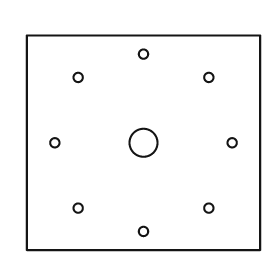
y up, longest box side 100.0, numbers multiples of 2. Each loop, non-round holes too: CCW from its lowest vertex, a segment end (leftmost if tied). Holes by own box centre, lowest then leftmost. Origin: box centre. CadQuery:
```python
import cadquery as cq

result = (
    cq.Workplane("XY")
    .moveTo(-50.0, -46.0)
    .lineTo(50.0, -46.0)
    .lineTo(50.0, 46.0)
    .lineTo(-50.0, 46.0)
    .close()
    .moveTo(0.0, -38.0)
    .circle(2.0)
    .moveTo(-28.0, -28.0)
    .circle(2.0)
    .moveTo(28.0, -28.0)
    .circle(2.0)
    .moveTo(-38.0, 0.0)
    .circle(2.0)
    .moveTo(0.0, 0.0)
    .circle(6.0)
    .moveTo(38.0, 0.0)
    .circle(2.0)
    .moveTo(-28.0, 28.0)
    .circle(2.0)
    .moveTo(28.0, 28.0)
    .circle(2.0)
    .moveTo(0.0, 38.0)
    .circle(2.0)
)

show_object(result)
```